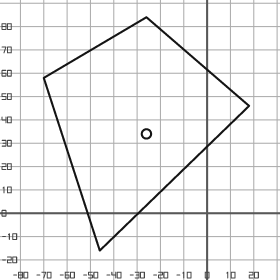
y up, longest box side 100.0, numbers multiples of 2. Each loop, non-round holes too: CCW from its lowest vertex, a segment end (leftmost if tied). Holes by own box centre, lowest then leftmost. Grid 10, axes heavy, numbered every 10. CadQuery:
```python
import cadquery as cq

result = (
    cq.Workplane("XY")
    .moveTo(-46.0, -16.0)
    .lineTo(18.0, 46.0)
    .lineTo(-26.0, 84.0)
    .lineTo(-70.0, 58.0)
    .close()
    .moveTo(-26.0, 34.0)
    .circle(2.0)
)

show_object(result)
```